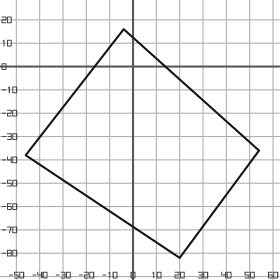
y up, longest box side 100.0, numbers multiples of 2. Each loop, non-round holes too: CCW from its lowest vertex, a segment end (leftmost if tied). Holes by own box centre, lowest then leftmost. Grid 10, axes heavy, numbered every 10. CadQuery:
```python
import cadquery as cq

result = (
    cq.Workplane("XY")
    .moveTo(20.0, -82.0)
    .lineTo(54.0, -36.0)
    .lineTo(-4.0, 16.0)
    .lineTo(-46.0, -38.0)
    .close()
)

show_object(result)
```